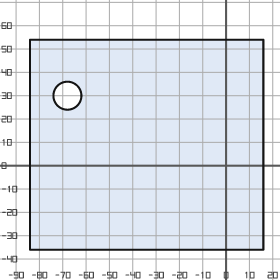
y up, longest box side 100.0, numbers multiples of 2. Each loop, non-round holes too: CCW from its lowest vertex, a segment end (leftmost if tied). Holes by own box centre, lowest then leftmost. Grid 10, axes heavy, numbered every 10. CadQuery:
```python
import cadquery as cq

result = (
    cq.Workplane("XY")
    .moveTo(-84.0, -36.0)
    .lineTo(16.0, -36.0)
    .lineTo(16.0, 54.0)
    .lineTo(-84.0, 54.0)
    .close()
    .moveTo(-68.0, 30.0)
    .circle(6.0)
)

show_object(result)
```